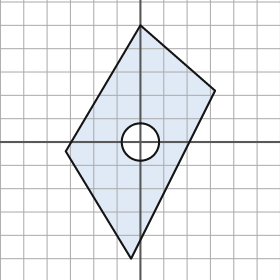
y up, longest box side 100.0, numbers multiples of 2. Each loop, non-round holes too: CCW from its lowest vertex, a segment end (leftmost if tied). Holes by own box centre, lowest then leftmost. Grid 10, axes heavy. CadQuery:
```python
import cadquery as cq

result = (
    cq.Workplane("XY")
    .moveTo(-4.0, -50.0)
    .lineTo(32.0, 22.0)
    .lineTo(0.0, 50.0)
    .lineTo(-32.0, -4.0)
    .close()
    .moveTo(0.0, 0.0)
    .circle(8.0)
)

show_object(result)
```